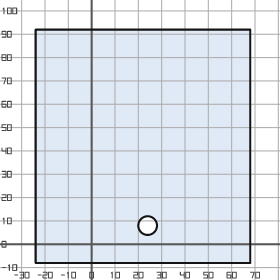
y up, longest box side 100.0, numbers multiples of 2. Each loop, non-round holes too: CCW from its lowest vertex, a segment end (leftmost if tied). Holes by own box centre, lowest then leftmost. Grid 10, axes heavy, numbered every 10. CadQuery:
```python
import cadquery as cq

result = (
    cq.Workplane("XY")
    .moveTo(-24.0, -8.0)
    .lineTo(68.0, -8.0)
    .lineTo(68.0, 92.0)
    .lineTo(-24.0, 92.0)
    .close()
    .moveTo(24.0, 8.0)
    .circle(4.0)
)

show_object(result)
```